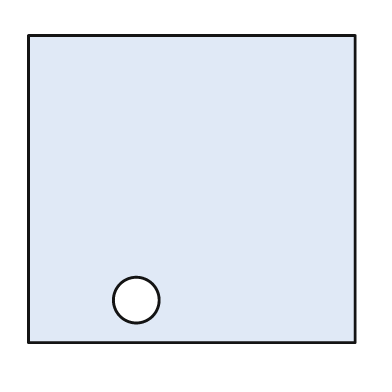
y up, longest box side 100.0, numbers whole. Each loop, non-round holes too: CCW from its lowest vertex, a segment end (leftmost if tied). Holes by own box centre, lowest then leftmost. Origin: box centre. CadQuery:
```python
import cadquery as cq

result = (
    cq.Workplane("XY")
    .moveTo(-50.0, -47.0)
    .lineTo(50.0, -47.0)
    .lineTo(50.0, 47.0)
    .lineTo(-50.0, 47.0)
    .close()
    .moveTo(-17.0, -34.0)
    .circle(7.0)
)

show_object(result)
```